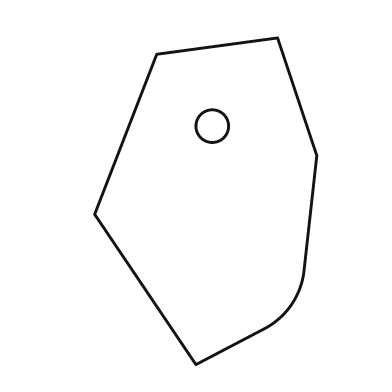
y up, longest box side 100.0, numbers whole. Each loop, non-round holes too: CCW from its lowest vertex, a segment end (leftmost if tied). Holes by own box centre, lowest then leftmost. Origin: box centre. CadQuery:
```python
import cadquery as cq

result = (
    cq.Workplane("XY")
    .moveTo(-3.0, -50.0)
    .lineTo(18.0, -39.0)
    .threePointArc((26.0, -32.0), (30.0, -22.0))
    .lineTo(34.0, 14.0)
    .lineTo(22.0, 50.0)
    .lineTo(-15.0, 45.0)
    .lineTo(-34.0, -4.0)
    .close()
    .moveTo(2.0, 23.0)
    .circle(5.0)
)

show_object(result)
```